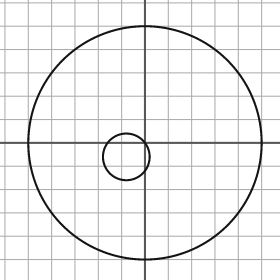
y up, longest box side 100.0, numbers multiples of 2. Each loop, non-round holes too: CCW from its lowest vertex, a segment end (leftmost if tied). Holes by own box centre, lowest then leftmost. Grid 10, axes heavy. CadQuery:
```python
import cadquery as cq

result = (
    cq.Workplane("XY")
    .moveTo(0.0, 0.0)
    .circle(50.0)
    .moveTo(-8.0, -6.0)
    .circle(10.0)
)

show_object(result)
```